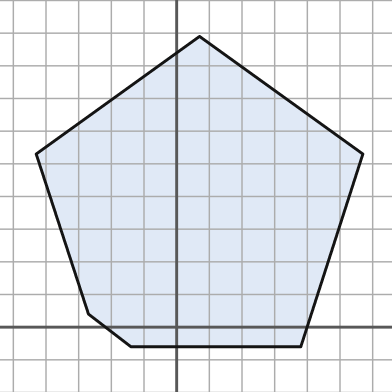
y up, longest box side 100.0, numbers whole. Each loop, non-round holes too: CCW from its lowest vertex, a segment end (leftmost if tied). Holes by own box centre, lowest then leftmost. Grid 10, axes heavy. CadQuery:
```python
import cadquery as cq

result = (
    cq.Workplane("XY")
    .moveTo(-14.0, -6.0)
    .lineTo(38.0, -6.0)
    .lineTo(57.0, 53.0)
    .lineTo(7.0, 89.0)
    .lineTo(-43.0, 53.0)
    .lineTo(-27.0, 4.0)
    .close()
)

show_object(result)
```